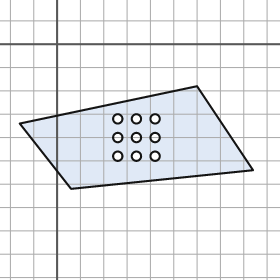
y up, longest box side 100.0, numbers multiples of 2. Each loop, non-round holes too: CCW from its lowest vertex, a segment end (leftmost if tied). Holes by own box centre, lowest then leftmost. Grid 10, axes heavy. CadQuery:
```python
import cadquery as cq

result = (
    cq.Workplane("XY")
    .moveTo(6.0, -62.0)
    .lineTo(84.0, -54.0)
    .lineTo(60.0, -18.0)
    .lineTo(-16.0, -34.0)
    .close()
    .moveTo(26.0, -48.0)
    .circle(2.0)
    .moveTo(34.0, -48.0)
    .circle(2.0)
    .moveTo(42.0, -48.0)
    .circle(2.0)
    .moveTo(26.0, -40.0)
    .circle(2.0)
    .moveTo(34.0, -40.0)
    .circle(2.0)
    .moveTo(42.0, -40.0)
    .circle(2.0)
    .moveTo(26.0, -32.0)
    .circle(2.0)
    .moveTo(34.0, -32.0)
    .circle(2.0)
    .moveTo(42.0, -32.0)
    .circle(2.0)
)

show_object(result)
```